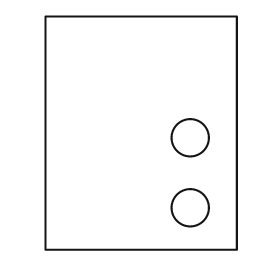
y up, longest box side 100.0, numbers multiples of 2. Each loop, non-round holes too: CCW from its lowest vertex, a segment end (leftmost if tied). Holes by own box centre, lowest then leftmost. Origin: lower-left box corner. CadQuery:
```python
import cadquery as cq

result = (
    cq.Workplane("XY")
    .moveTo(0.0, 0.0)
    .lineTo(82.0, 0.0)
    .lineTo(82.0, 100.0)
    .lineTo(0.0, 100.0)
    .close()
    .moveTo(62.0, 18.0)
    .circle(8.0)
    .moveTo(62.0, 48.0)
    .circle(8.0)
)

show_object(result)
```